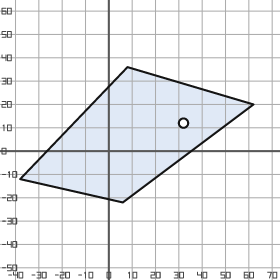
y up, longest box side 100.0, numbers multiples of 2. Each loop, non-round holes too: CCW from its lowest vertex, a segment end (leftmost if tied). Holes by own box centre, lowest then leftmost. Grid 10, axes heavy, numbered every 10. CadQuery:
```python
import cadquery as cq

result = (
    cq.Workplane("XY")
    .moveTo(6.0, -22.0)
    .lineTo(62.0, 20.0)
    .lineTo(8.0, 36.0)
    .lineTo(-38.0, -12.0)
    .close()
    .moveTo(32.0, 12.0)
    .circle(2.0)
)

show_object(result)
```